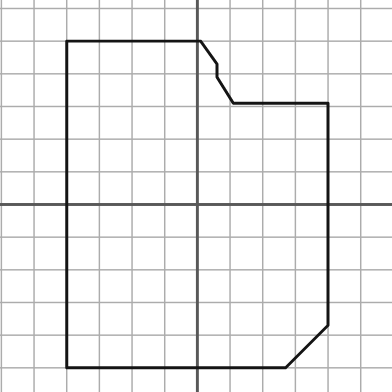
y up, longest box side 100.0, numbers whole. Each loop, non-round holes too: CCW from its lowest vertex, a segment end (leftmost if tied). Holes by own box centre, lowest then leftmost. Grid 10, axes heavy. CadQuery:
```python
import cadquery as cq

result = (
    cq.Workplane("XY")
    .moveTo(-40.0, -50.0)
    .lineTo(27.0, -50.0)
    .lineTo(40.0, -37.0)
    .lineTo(40.0, 31.0)
    .lineTo(11.0, 31.0)
    .lineTo(6.0, 39.0)
    .lineTo(6.0, 43.0)
    .lineTo(1.0, 50.0)
    .lineTo(-40.0, 50.0)
    .close()
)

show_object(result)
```